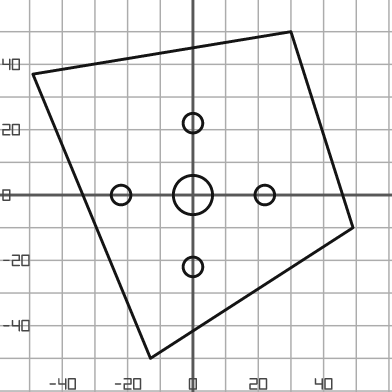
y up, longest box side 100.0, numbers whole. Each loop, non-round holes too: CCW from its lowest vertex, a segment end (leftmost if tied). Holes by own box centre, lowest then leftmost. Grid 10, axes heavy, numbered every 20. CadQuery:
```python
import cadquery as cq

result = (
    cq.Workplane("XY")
    .moveTo(-13.0, -50.0)
    .lineTo(49.0, -10.0)
    .lineTo(30.0, 50.0)
    .lineTo(-49.0, 37.0)
    .close()
    .moveTo(0.0, -22.0)
    .circle(3.0)
    .moveTo(-22.0, 0.0)
    .circle(3.0)
    .moveTo(0.0, 0.0)
    .circle(6.0)
    .moveTo(22.0, 0.0)
    .circle(3.0)
    .moveTo(0.0, 22.0)
    .circle(3.0)
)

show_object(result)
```